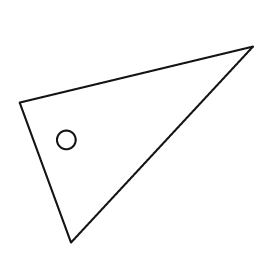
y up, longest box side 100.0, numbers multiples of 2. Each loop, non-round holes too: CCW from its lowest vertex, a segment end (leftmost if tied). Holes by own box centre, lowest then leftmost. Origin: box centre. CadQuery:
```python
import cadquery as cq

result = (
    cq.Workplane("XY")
    .moveTo(-28.0, -42.0)
    .lineTo(50.0, 42.0)
    .lineTo(-50.0, 18.0)
    .close()
    .moveTo(-30.0, 2.0)
    .circle(4.0)
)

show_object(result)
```